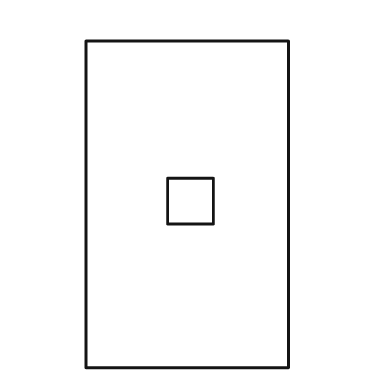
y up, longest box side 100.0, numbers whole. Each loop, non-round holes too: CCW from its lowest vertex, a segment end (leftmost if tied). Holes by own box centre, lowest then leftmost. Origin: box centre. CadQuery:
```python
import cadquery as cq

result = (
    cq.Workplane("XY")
    .moveTo(-31.0, -50.0)
    .lineTo(31.0, -50.0)
    .lineTo(31.0, 50.0)
    .lineTo(-31.0, 50.0)
    .close()
    .moveTo(-6.0, -6.0)
    .lineTo(8.0, -6.0)
    .lineTo(8.0, 8.0)
    .lineTo(-6.0, 8.0)
    .close()
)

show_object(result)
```